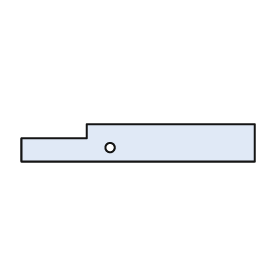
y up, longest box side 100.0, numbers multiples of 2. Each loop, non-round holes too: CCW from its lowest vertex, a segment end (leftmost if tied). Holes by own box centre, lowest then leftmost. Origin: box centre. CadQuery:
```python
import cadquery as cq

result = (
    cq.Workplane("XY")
    .moveTo(-50.0, -8.0)
    .lineTo(50.0, -8.0)
    .lineTo(50.0, 8.0)
    .lineTo(-22.0, 8.0)
    .lineTo(-22.0, 2.0)
    .lineTo(-50.0, 2.0)
    .close()
    .moveTo(-12.0, -2.0)
    .circle(2.0)
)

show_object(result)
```